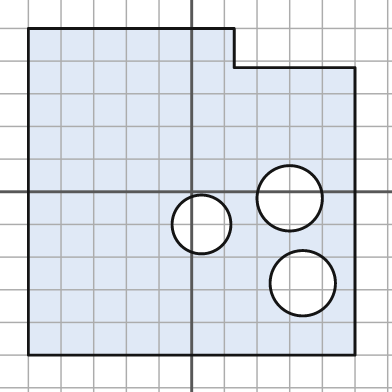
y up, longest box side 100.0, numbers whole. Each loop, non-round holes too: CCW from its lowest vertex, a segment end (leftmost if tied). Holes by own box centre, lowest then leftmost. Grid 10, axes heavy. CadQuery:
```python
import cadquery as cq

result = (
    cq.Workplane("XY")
    .moveTo(-50.0, -50.0)
    .lineTo(50.0, -50.0)
    .lineTo(50.0, 38.0)
    .lineTo(13.0, 38.0)
    .lineTo(13.0, 50.0)
    .lineTo(-50.0, 50.0)
    .close()
    .moveTo(34.0, -28.0)
    .circle(10.0)
    .moveTo(3.0, -10.0)
    .circle(9.0)
    .moveTo(30.0, -2.0)
    .circle(10.0)
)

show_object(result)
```